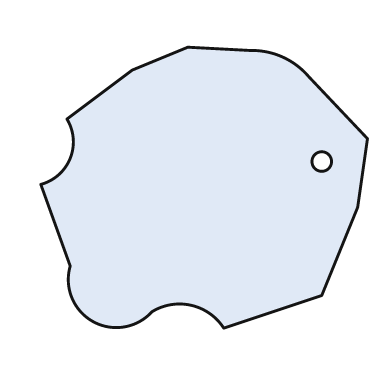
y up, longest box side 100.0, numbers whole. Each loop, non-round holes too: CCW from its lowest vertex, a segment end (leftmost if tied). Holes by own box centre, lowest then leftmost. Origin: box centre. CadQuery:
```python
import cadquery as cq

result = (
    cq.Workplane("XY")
    .moveTo(6.0, -43.0)
    .lineTo(36.0, -33.0)
    .lineTo(47.0, -6.0)
    .lineTo(50.0, 15.0)
    .lineTo(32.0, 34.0)
    .threePointArc((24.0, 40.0), (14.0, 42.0))
    .lineTo(-5.0, 43.0)
    .lineTo(-22.0, 36.0)
    .lineTo(-42.0, 21.0)
    .threePointArc((-41.0, 9.0), (-50.0, 1.0))
    .lineTo(-41.0, -24.0)
    .threePointArc((-34.0, -41.0), (-16.0, -38.0))
    .threePointArc((-4.0, -36.0), (6.0, -43.0))
    .close()
    .moveTo(36.0, 8.0)
    .circle(3.0)
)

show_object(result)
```